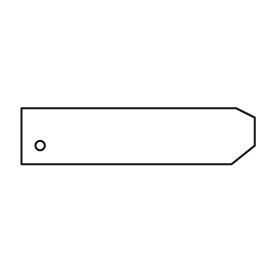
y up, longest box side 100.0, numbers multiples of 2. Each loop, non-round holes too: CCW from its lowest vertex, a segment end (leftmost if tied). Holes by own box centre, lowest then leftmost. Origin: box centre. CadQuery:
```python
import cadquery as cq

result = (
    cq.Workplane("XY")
    .moveTo(-50.0, -12.0)
    .lineTo(40.0, -12.0)
    .lineTo(50.0, -4.0)
    .lineTo(50.0, 8.0)
    .lineTo(42.0, 12.0)
    .lineTo(-50.0, 12.0)
    .close()
    .moveTo(-42.0, -4.0)
    .circle(2.0)
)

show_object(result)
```